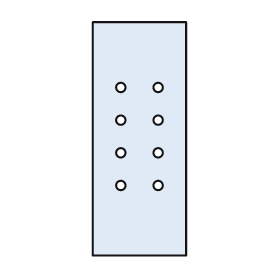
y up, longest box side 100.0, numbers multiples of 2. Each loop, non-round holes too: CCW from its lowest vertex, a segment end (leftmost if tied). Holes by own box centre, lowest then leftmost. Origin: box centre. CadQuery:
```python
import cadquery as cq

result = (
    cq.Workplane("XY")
    .moveTo(-20.0, -50.0)
    .lineTo(20.0, -50.0)
    .lineTo(20.0, 50.0)
    .lineTo(-20.0, 50.0)
    .close()
    .moveTo(-8.0, -20.0)
    .circle(2.0)
    .moveTo(8.0, -20.0)
    .circle(2.0)
    .moveTo(-8.0, -6.0)
    .circle(2.0)
    .moveTo(8.0, -6.0)
    .circle(2.0)
    .moveTo(-8.0, 8.0)
    .circle(2.0)
    .moveTo(8.0, 8.0)
    .circle(2.0)
    .moveTo(-8.0, 22.0)
    .circle(2.0)
    .moveTo(8.0, 22.0)
    .circle(2.0)
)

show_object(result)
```